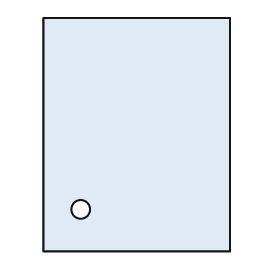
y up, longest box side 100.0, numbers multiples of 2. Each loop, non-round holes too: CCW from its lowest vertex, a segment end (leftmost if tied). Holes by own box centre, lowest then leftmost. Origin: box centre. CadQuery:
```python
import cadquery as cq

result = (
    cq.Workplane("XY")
    .moveTo(-40.0, -50.0)
    .lineTo(40.0, -50.0)
    .lineTo(40.0, 50.0)
    .lineTo(-40.0, 50.0)
    .close()
    .moveTo(-24.0, -32.0)
    .circle(4.0)
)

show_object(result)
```